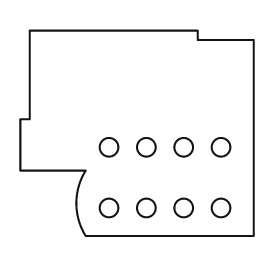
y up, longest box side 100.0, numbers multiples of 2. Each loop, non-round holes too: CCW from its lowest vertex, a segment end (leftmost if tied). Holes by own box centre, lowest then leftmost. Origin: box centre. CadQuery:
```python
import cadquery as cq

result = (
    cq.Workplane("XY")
    .moveTo(-22.0, -44.0)
    .lineTo(50.0, -44.0)
    .lineTo(50.0, 40.0)
    .lineTo(26.0, 40.0)
    .lineTo(26.0, 44.0)
    .lineTo(-46.0, 44.0)
    .lineTo(-46.0, 6.0)
    .lineTo(-50.0, 6.0)
    .lineTo(-50.0, -16.0)
    .lineTo(-22.0, -16.0)
    .threePointArc((-26.0, -30.0), (-22.0, -44.0))
    .close()
    .moveTo(-12.0, -32.0)
    .circle(4.0)
    .moveTo(4.0, -32.0)
    .circle(4.0)
    .moveTo(20.0, -32.0)
    .circle(4.0)
    .moveTo(36.0, -32.0)
    .circle(4.0)
    .moveTo(-12.0, -6.0)
    .circle(4.0)
    .moveTo(4.0, -6.0)
    .circle(4.0)
    .moveTo(20.0, -6.0)
    .circle(4.0)
    .moveTo(36.0, -6.0)
    .circle(4.0)
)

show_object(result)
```